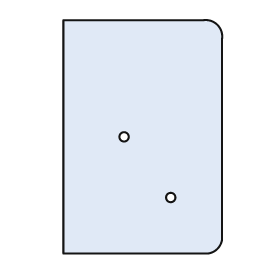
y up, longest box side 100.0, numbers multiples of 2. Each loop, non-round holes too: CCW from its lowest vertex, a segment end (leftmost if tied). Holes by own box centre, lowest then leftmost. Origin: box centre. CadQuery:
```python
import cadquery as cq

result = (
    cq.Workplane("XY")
    .moveTo(-34.0, -50.0)
    .lineTo(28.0, -50.0)
    .threePointArc((32.0, -48.0), (34.0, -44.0))
    .lineTo(34.0, 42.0)
    .threePointArc((32.0, 48.0), (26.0, 50.0))
    .lineTo(-34.0, 50.0)
    .close()
    .moveTo(12.0, -26.0)
    .circle(2.0)
    .moveTo(-8.0, 0.0)
    .circle(2.0)
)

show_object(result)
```